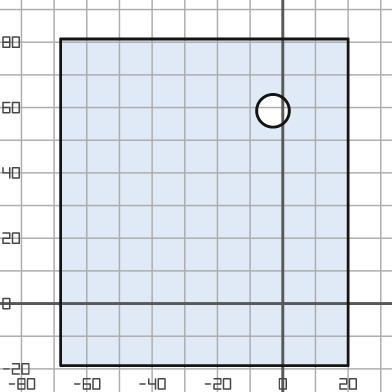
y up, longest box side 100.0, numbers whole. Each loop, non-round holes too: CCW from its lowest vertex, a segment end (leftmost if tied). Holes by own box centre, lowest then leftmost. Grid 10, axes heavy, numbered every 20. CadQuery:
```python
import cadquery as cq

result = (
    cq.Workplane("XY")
    .moveTo(-68.0, -19.0)
    .lineTo(20.0, -19.0)
    .lineTo(20.0, 81.0)
    .lineTo(-68.0, 81.0)
    .close()
    .moveTo(-3.0, 59.0)
    .circle(5.0)
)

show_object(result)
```